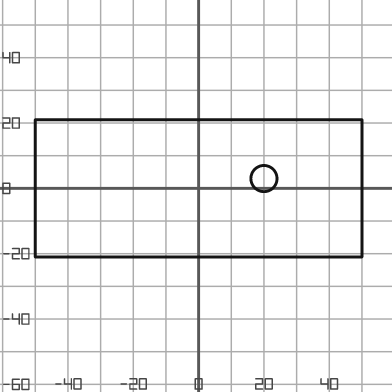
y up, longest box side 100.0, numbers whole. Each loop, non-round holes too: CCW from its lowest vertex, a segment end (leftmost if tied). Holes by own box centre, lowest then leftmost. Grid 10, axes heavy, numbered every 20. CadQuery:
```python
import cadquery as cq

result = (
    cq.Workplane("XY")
    .moveTo(-50.0, -21.0)
    .lineTo(50.0, -21.0)
    .lineTo(50.0, 21.0)
    .lineTo(-50.0, 21.0)
    .close()
    .moveTo(20.0, 3.0)
    .circle(4.0)
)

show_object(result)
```